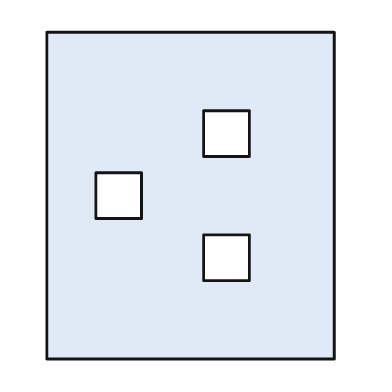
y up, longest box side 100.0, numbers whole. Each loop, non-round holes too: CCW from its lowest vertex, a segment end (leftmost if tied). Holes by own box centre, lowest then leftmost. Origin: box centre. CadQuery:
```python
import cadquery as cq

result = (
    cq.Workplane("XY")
    .moveTo(-44.0, -50.0)
    .lineTo(44.0, -50.0)
    .lineTo(44.0, 50.0)
    .lineTo(-44.0, 50.0)
    .close()
    .moveTo(4.0, -26.0)
    .lineTo(18.0, -26.0)
    .lineTo(18.0, -12.0)
    .lineTo(4.0, -12.0)
    .close()
    .moveTo(-29.0, -7.0)
    .lineTo(-15.0, -7.0)
    .lineTo(-15.0, 7.0)
    .lineTo(-29.0, 7.0)
    .close()
    .moveTo(4.0, 12.0)
    .lineTo(18.0, 12.0)
    .lineTo(18.0, 26.0)
    .lineTo(4.0, 26.0)
    .close()
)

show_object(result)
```